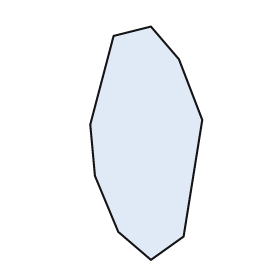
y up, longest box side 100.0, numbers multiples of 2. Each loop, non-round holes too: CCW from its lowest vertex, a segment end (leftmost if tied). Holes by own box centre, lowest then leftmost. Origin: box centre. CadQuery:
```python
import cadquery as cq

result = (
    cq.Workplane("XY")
    .moveTo(2.0, -50.0)
    .lineTo(16.0, -40.0)
    .lineTo(24.0, 10.0)
    .lineTo(14.0, 36.0)
    .lineTo(2.0, 50.0)
    .lineTo(-14.0, 46.0)
    .lineTo(-24.0, 8.0)
    .lineTo(-22.0, -14.0)
    .lineTo(-12.0, -38.0)
    .close()
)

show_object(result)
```